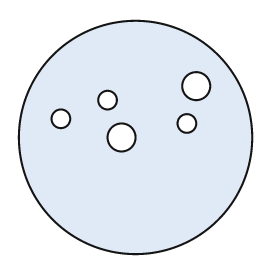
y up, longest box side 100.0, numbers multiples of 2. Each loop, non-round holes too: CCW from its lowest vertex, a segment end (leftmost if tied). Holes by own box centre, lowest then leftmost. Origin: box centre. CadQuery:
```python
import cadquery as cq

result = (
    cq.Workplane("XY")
    .moveTo(0.0, 0.0)
    .circle(50.0)
    .moveTo(-6.0, 0.0)
    .circle(6.0)
    .moveTo(22.0, 6.0)
    .circle(4.0)
    .moveTo(-32.0, 8.0)
    .circle(4.0)
    .moveTo(-12.0, 16.0)
    .circle(4.0)
    .moveTo(26.0, 22.0)
    .circle(6.0)
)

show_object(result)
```